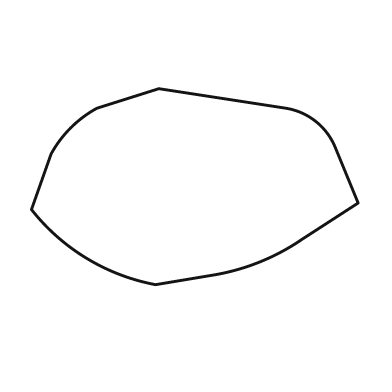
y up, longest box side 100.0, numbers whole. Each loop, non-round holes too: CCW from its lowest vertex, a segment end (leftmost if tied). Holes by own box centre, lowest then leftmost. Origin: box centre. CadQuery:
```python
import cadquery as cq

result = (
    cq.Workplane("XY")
    .moveTo(-12.0, -30.0)
    .lineTo(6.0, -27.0)
    .threePointArc((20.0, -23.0), (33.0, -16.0))
    .lineTo(50.0, -5.0)
    .lineTo(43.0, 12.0)
    .threePointArc((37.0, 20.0), (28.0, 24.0))
    .lineTo(-11.0, 30.0)
    .lineTo(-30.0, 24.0)
    .threePointArc((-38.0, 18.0), (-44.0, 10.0))
    .lineTo(-50.0, -7.0)
    .threePointArc((-33.0, -22.0), (-12.0, -30.0))
    .close()
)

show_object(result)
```